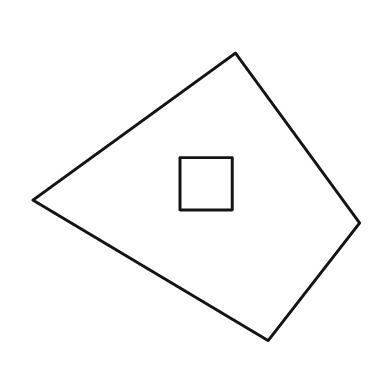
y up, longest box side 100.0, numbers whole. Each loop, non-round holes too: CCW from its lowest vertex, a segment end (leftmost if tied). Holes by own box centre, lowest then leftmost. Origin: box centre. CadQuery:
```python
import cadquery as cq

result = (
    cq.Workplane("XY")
    .moveTo(22.0, -44.0)
    .lineTo(50.0, -8.0)
    .lineTo(12.0, 44.0)
    .lineTo(-50.0, -1.0)
    .close()
    .moveTo(-5.0, -4.0)
    .lineTo(11.0, -4.0)
    .lineTo(11.0, 12.0)
    .lineTo(-5.0, 12.0)
    .close()
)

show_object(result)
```